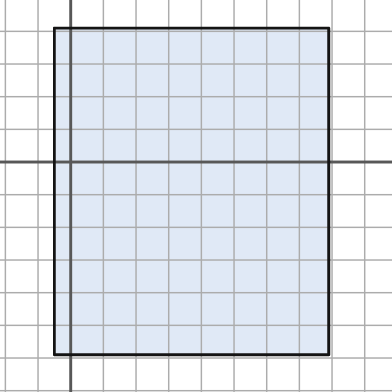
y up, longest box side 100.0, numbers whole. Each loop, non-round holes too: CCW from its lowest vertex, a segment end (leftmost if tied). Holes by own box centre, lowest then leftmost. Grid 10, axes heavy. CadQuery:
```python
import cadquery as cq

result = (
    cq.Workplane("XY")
    .moveTo(-5.0, -59.0)
    .lineTo(79.0, -59.0)
    .lineTo(79.0, 41.0)
    .lineTo(-5.0, 41.0)
    .close()
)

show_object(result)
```